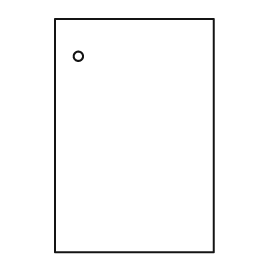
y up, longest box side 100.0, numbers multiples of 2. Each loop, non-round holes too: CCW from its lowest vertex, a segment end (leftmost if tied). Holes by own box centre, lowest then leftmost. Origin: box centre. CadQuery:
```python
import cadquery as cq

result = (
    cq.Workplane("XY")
    .moveTo(-34.0, -50.0)
    .lineTo(34.0, -50.0)
    .lineTo(34.0, 50.0)
    .lineTo(-34.0, 50.0)
    .close()
    .moveTo(-24.0, 34.0)
    .circle(2.0)
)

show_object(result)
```